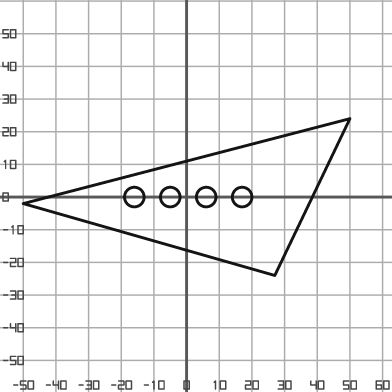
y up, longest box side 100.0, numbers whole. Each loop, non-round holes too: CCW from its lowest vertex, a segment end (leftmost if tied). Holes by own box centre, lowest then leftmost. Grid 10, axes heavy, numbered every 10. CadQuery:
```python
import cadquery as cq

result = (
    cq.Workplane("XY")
    .moveTo(27.0, -24.0)
    .lineTo(50.0, 24.0)
    .lineTo(-50.0, -2.0)
    .close()
    .moveTo(-16.0, 0.0)
    .circle(3.0)
    .moveTo(-5.0, 0.0)
    .circle(3.0)
    .moveTo(6.0, 0.0)
    .circle(3.0)
    .moveTo(17.0, 0.0)
    .circle(3.0)
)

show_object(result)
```